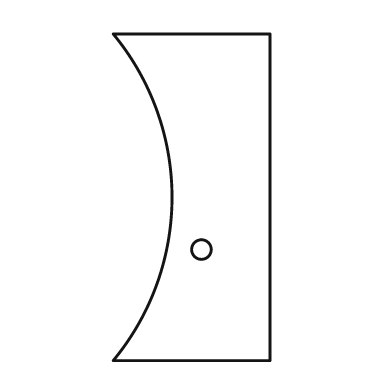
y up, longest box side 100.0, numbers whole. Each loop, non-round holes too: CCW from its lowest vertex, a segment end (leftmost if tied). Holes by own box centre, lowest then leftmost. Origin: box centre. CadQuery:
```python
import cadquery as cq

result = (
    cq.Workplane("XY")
    .moveTo(-24.0, -50.0)
    .lineTo(24.0, -50.0)
    .lineTo(24.0, 50.0)
    .lineTo(-24.0, 50.0)
    .threePointArc((-6.0, 0.0), (-24.0, -50.0))
    .close()
    .moveTo(3.0, -16.0)
    .circle(3.0)
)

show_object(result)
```